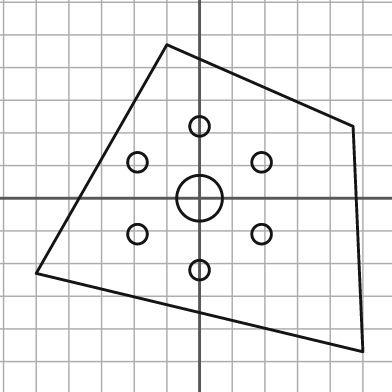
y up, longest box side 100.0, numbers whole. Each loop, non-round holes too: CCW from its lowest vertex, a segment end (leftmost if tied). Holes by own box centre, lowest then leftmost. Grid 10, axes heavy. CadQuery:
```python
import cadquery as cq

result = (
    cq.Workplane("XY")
    .moveTo(50.0, -47.0)
    .lineTo(47.0, 22.0)
    .lineTo(-10.0, 47.0)
    .lineTo(-50.0, -23.0)
    .close()
    .moveTo(0.0, -22.0)
    .circle(3.0)
    .moveTo(-19.0, -11.0)
    .circle(3.0)
    .moveTo(19.0, -11.0)
    .circle(3.0)
    .moveTo(0.0, 0.0)
    .circle(7.0)
    .moveTo(-19.0, 11.0)
    .circle(3.0)
    .moveTo(19.0, 11.0)
    .circle(3.0)
    .moveTo(0.0, 22.0)
    .circle(3.0)
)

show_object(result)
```